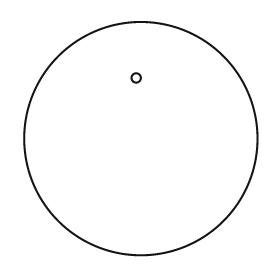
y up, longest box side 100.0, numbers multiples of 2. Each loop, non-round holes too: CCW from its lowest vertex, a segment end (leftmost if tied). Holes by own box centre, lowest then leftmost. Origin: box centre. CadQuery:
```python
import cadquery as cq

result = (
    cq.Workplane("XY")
    .moveTo(0.0, 0.0)
    .circle(50.0)
    .moveTo(-2.0, 26.0)
    .circle(2.0)
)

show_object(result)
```